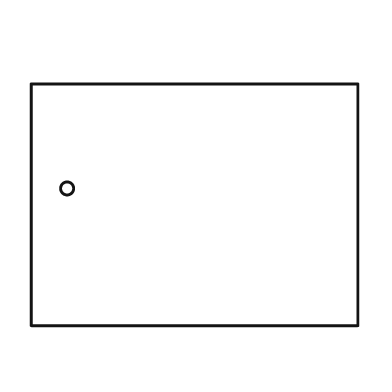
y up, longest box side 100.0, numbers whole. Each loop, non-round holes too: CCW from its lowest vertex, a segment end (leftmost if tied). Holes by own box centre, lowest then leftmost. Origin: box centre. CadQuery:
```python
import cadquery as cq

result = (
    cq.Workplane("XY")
    .moveTo(-50.0, -37.0)
    .lineTo(50.0, -37.0)
    .lineTo(50.0, 37.0)
    .lineTo(-50.0, 37.0)
    .close()
    .moveTo(-39.0, 5.0)
    .circle(2.0)
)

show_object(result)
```